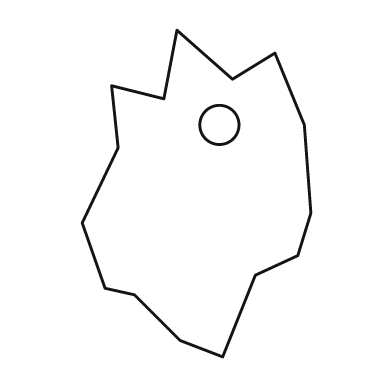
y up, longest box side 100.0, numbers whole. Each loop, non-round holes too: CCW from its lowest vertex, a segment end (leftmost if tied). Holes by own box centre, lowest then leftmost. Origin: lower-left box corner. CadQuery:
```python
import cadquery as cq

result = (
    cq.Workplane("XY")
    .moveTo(43.0, 0.0)
    .lineTo(53.0, 25.0)
    .lineTo(66.0, 31.0)
    .lineTo(70.0, 44.0)
    .lineTo(68.0, 71.0)
    .lineTo(59.0, 93.0)
    .lineTo(46.0, 85.0)
    .lineTo(29.0, 100.0)
    .lineTo(25.0, 79.0)
    .lineTo(9.0, 83.0)
    .lineTo(11.0, 64.0)
    .lineTo(0.0, 41.0)
    .lineTo(7.0, 21.0)
    .lineTo(16.0, 19.0)
    .lineTo(30.0, 5.0)
    .close()
    .moveTo(42.0, 71.0)
    .circle(6.0)
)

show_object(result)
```